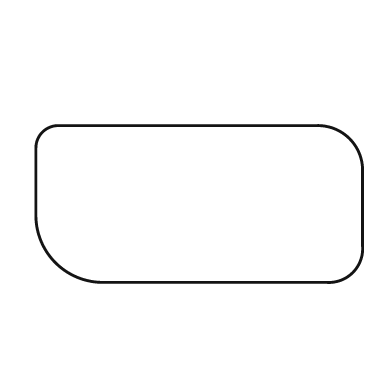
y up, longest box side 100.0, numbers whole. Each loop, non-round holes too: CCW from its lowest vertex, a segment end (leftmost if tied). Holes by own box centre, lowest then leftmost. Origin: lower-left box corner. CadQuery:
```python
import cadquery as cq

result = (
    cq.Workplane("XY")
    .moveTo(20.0, 0.0)
    .lineTo(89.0, 0.0)
    .threePointArc((97.0, 3.0), (100.0, 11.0))
    .lineTo(100.0, 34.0)
    .threePointArc((96.0, 44.0), (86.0, 48.0))
    .lineTo(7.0, 48.0)
    .threePointArc((2.0, 46.0), (0.0, 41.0))
    .lineTo(0.0, 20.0)
    .threePointArc((6.0, 6.0), (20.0, 0.0))
    .close()
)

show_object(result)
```